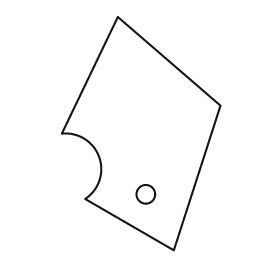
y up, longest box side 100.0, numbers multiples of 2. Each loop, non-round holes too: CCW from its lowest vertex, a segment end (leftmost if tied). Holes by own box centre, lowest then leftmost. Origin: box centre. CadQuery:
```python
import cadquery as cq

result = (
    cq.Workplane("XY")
    .moveTo(14.0, -50.0)
    .lineTo(34.0, 12.0)
    .lineTo(-10.0, 50.0)
    .lineTo(-34.0, 0.0)
    .threePointArc((-18.0, -10.0), (-24.0, -28.0))
    .close()
    .moveTo(2.0, -26.0)
    .circle(4.0)
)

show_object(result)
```